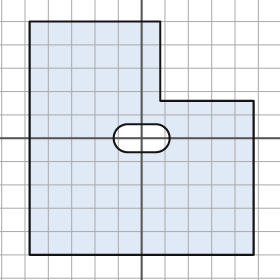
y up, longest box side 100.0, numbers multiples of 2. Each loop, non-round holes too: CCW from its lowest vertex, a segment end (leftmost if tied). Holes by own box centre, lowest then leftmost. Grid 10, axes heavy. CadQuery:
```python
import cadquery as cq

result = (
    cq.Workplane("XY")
    .moveTo(-48.0, -50.0)
    .lineTo(48.0, -50.0)
    .lineTo(48.0, 16.0)
    .lineTo(8.0, 16.0)
    .lineTo(8.0, 50.0)
    .lineTo(-48.0, 50.0)
    .close()
    .moveTo(-6.0, -6.0)
    .lineTo(6.0, -6.0)
    .threePointArc((12.0, 0.0), (6.0, 6.0))
    .lineTo(-6.0, 6.0)
    .threePointArc((-12.0, 0.0), (-6.0, -6.0))
    .close()
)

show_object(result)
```